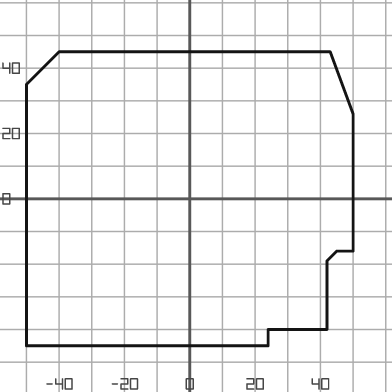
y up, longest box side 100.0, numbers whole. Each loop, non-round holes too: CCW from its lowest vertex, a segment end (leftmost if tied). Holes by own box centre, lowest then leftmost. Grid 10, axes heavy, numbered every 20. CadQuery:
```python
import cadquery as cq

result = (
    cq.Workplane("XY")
    .moveTo(-50.0, -45.0)
    .lineTo(24.0, -45.0)
    .lineTo(24.0, -40.0)
    .lineTo(42.0, -40.0)
    .lineTo(42.0, -19.0)
    .lineTo(45.0, -16.0)
    .lineTo(50.0, -16.0)
    .lineTo(50.0, 26.0)
    .lineTo(43.0, 45.0)
    .lineTo(-40.0, 45.0)
    .lineTo(-50.0, 35.0)
    .close()
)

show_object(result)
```